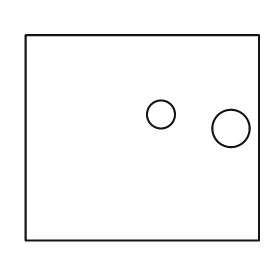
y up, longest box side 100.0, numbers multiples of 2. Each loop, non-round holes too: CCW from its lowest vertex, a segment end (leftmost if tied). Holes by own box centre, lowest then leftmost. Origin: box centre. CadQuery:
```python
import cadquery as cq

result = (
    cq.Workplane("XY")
    .moveTo(-50.0, -44.0)
    .lineTo(50.0, -44.0)
    .lineTo(50.0, 44.0)
    .lineTo(-50.0, 44.0)
    .close()
    .moveTo(38.0, 4.0)
    .circle(8.0)
    .moveTo(8.0, 10.0)
    .circle(6.0)
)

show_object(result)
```